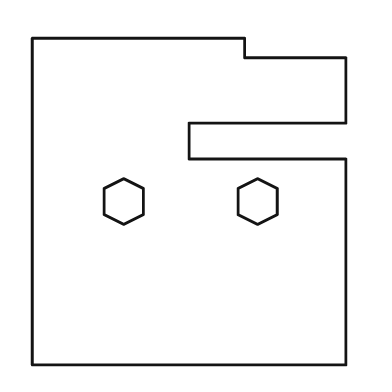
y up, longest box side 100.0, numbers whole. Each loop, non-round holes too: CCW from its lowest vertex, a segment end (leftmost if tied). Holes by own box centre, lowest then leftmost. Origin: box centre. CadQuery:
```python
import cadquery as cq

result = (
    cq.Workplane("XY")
    .moveTo(-48.0, -50.0)
    .lineTo(48.0, -50.0)
    .lineTo(48.0, 13.0)
    .lineTo(0.0, 13.0)
    .lineTo(0.0, 24.0)
    .lineTo(48.0, 24.0)
    .lineTo(48.0, 44.0)
    .lineTo(17.0, 44.0)
    .lineTo(17.0, 50.0)
    .lineTo(-48.0, 50.0)
    .close()
    .moveTo(-20.0, -7.0)
    .lineTo(-14.0, -4.0)
    .lineTo(-14.0, 4.0)
    .lineTo(-20.0, 7.0)
    .lineTo(-26.0, 4.0)
    .lineTo(-26.0, -4.0)
    .close()
    .moveTo(21.0, -7.0)
    .lineTo(27.0, -4.0)
    .lineTo(27.0, 4.0)
    .lineTo(21.0, 7.0)
    .lineTo(15.0, 4.0)
    .lineTo(15.0, -4.0)
    .close()
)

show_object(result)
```